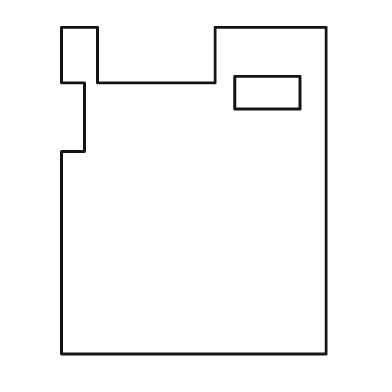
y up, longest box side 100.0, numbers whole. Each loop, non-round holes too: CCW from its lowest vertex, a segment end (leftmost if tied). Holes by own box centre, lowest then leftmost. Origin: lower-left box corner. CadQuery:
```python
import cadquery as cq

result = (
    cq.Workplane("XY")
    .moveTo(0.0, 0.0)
    .lineTo(81.0, 0.0)
    .lineTo(81.0, 100.0)
    .lineTo(47.0, 100.0)
    .lineTo(47.0, 83.0)
    .lineTo(11.0, 83.0)
    .lineTo(11.0, 100.0)
    .lineTo(0.0, 100.0)
    .lineTo(0.0, 83.0)
    .lineTo(7.0, 83.0)
    .lineTo(7.0, 62.0)
    .lineTo(0.0, 62.0)
    .close()
    .moveTo(53.0, 75.0)
    .lineTo(73.0, 75.0)
    .lineTo(73.0, 85.0)
    .lineTo(53.0, 85.0)
    .close()
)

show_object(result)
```